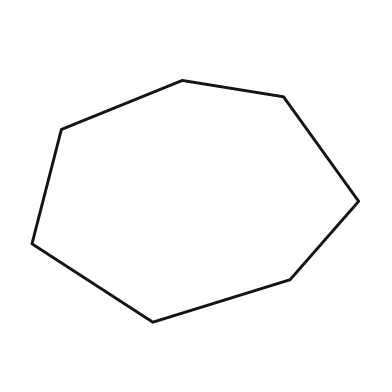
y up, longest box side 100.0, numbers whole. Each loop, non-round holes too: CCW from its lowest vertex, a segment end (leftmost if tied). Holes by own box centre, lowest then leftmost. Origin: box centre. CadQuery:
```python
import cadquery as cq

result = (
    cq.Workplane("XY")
    .moveTo(-13.0, -37.0)
    .lineTo(29.0, -24.0)
    .lineTo(50.0, 0.0)
    .lineTo(27.0, 32.0)
    .lineTo(-4.0, 37.0)
    .lineTo(-41.0, 22.0)
    .lineTo(-50.0, -13.0)
    .close()
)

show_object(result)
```